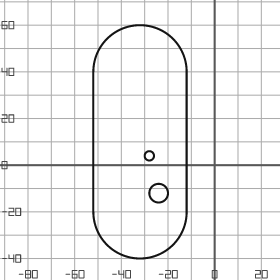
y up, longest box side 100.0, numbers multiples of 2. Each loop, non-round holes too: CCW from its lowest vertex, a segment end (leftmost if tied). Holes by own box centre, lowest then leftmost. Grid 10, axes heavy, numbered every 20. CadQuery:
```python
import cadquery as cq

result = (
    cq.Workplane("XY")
    .moveTo(-52.0, -20.0)
    .threePointArc((-32.0, -40.0), (-12.0, -20.0))
    .lineTo(-12.0, 40.0)
    .threePointArc((-32.0, 60.0), (-52.0, 40.0))
    .close()
    .moveTo(-24.0, -12.0)
    .circle(4.0)
    .moveTo(-28.0, 4.0)
    .circle(2.0)
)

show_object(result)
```